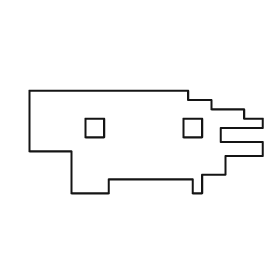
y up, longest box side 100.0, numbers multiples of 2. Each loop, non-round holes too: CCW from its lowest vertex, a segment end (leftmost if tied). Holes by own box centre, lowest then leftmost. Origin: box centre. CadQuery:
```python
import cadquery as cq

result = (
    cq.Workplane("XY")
    .moveTo(-32.0, -22.0)
    .lineTo(-16.0, -22.0)
    .lineTo(-16.0, -16.0)
    .lineTo(20.0, -16.0)
    .lineTo(20.0, -22.0)
    .lineTo(24.0, -22.0)
    .lineTo(24.0, -14.0)
    .lineTo(34.0, -14.0)
    .lineTo(34.0, -6.0)
    .lineTo(50.0, -6.0)
    .lineTo(50.0, 0.0)
    .lineTo(32.0, 0.0)
    .lineTo(32.0, 6.0)
    .lineTo(50.0, 6.0)
    .lineTo(50.0, 10.0)
    .lineTo(42.0, 10.0)
    .lineTo(42.0, 14.0)
    .lineTo(28.0, 14.0)
    .lineTo(28.0, 18.0)
    .lineTo(18.0, 18.0)
    .lineTo(18.0, 22.0)
    .lineTo(-50.0, 22.0)
    .lineTo(-50.0, -4.0)
    .lineTo(-32.0, -4.0)
    .close()
    .moveTo(-26.0, 2.0)
    .lineTo(-18.0, 2.0)
    .lineTo(-18.0, 10.0)
    .lineTo(-26.0, 10.0)
    .close()
    .moveTo(16.0, 2.0)
    .lineTo(24.0, 2.0)
    .lineTo(24.0, 10.0)
    .lineTo(16.0, 10.0)
    .close()
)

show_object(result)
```